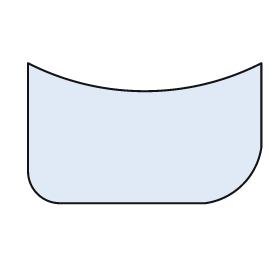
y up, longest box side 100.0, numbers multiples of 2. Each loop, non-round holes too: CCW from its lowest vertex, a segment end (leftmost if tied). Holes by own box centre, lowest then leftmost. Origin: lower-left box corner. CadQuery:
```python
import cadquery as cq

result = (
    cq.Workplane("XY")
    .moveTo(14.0, 0.0)
    .lineTo(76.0, 0.0)
    .threePointArc((92.0, 8.0), (100.0, 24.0))
    .lineTo(100.0, 60.0)
    .threePointArc((50.0, 48.0), (0.0, 60.0))
    .lineTo(0.0, 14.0)
    .threePointArc((4.0, 4.0), (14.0, 0.0))
    .close()
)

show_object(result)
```